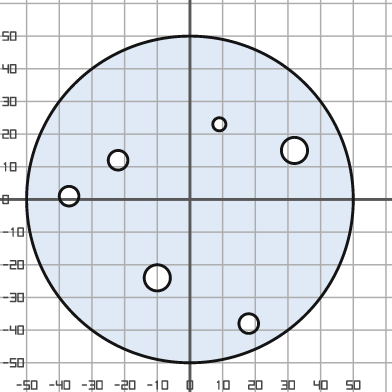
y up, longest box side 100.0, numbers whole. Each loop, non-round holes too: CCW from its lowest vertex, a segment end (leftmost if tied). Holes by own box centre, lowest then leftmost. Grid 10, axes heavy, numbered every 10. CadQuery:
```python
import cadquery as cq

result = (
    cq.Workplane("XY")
    .moveTo(0.0, 0.0)
    .circle(50.0)
    .moveTo(18.0, -38.0)
    .circle(3.0)
    .moveTo(-10.0, -24.0)
    .circle(4.0)
    .moveTo(-37.0, 1.0)
    .circle(3.0)
    .moveTo(-22.0, 12.0)
    .circle(3.0)
    .moveTo(32.0, 15.0)
    .circle(4.0)
    .moveTo(9.0, 23.0)
    .circle(2.0)
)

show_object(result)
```